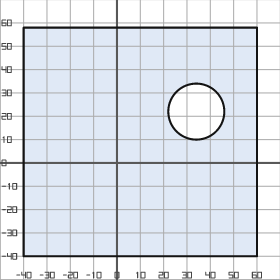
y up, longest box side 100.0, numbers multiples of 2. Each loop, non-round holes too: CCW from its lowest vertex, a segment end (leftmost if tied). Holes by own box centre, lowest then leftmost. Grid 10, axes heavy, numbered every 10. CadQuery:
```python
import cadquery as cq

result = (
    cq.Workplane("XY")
    .moveTo(-40.0, -40.0)
    .lineTo(60.0, -40.0)
    .lineTo(60.0, 58.0)
    .lineTo(-40.0, 58.0)
    .close()
    .moveTo(34.0, 22.0)
    .circle(12.0)
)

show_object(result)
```